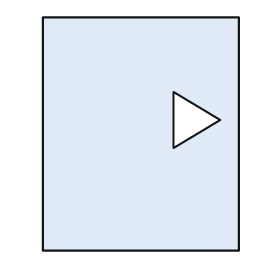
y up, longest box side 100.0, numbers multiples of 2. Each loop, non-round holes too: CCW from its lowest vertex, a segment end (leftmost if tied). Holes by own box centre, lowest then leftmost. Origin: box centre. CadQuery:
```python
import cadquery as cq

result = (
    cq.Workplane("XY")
    .moveTo(-42.0, -50.0)
    .lineTo(42.0, -50.0)
    .lineTo(42.0, 50.0)
    .lineTo(-42.0, 50.0)
    .close()
    .moveTo(14.0, -6.0)
    .lineTo(34.0, 6.0)
    .lineTo(14.0, 18.0)
    .close()
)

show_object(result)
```